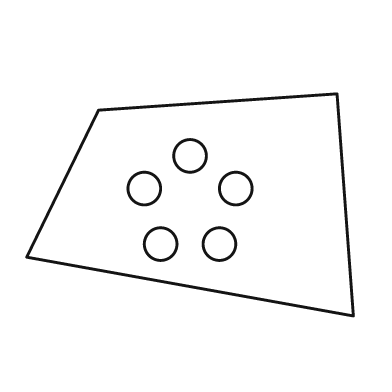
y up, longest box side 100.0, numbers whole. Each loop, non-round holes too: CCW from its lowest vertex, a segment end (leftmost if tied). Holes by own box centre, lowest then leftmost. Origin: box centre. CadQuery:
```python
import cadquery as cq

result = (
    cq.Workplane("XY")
    .moveTo(50.0, -34.0)
    .lineTo(45.0, 34.0)
    .lineTo(-28.0, 29.0)
    .lineTo(-50.0, -16.0)
    .close()
    .moveTo(-9.0, -12.0)
    .circle(5.0)
    .moveTo(9.0, -12.0)
    .circle(5.0)
    .moveTo(-14.0, 5.0)
    .circle(5.0)
    .moveTo(14.0, 5.0)
    .circle(5.0)
    .moveTo(0.0, 15.0)
    .circle(5.0)
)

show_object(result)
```